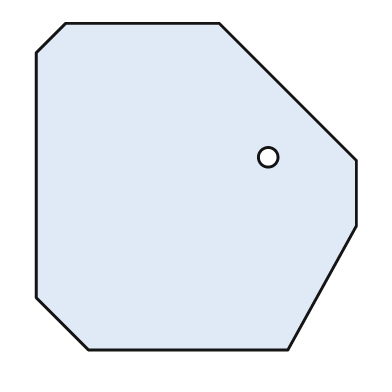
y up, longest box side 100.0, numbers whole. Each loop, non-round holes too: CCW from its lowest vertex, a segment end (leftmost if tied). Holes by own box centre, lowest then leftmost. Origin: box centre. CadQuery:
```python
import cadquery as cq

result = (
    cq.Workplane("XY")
    .moveTo(-33.0, -50.0)
    .lineTo(28.0, -50.0)
    .lineTo(49.0, -12.0)
    .lineTo(49.0, 8.0)
    .lineTo(7.0, 50.0)
    .lineTo(-40.0, 50.0)
    .lineTo(-49.0, 41.0)
    .lineTo(-49.0, -34.0)
    .close()
    .moveTo(22.0, 9.0)
    .circle(3.0)
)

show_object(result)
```